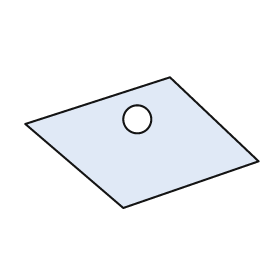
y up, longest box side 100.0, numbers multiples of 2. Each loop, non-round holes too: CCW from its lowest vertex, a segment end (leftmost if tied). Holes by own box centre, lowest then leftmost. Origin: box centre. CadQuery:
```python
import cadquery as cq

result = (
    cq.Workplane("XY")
    .moveTo(-8.0, -28.0)
    .lineTo(50.0, -8.0)
    .lineTo(12.0, 28.0)
    .lineTo(-50.0, 8.0)
    .close()
    .moveTo(-2.0, 10.0)
    .circle(6.0)
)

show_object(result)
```